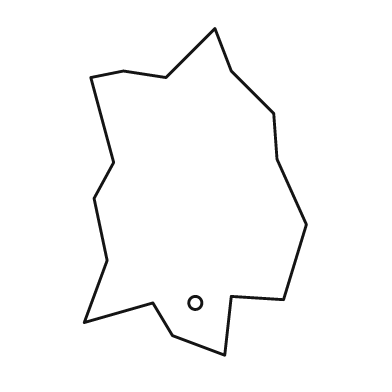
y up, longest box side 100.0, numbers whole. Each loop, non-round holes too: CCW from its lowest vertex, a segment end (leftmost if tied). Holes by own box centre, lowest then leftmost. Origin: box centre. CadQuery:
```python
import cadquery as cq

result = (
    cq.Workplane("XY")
    .moveTo(9.0, -50.0)
    .lineTo(11.0, -32.0)
    .lineTo(27.0, -33.0)
    .lineTo(34.0, -10.0)
    .lineTo(25.0, 10.0)
    .lineTo(24.0, 24.0)
    .lineTo(11.0, 37.0)
    .lineTo(6.0, 50.0)
    .lineTo(-9.0, 35.0)
    .lineTo(-22.0, 37.0)
    .lineTo(-32.0, 35.0)
    .lineTo(-25.0, 9.0)
    .lineTo(-31.0, -2.0)
    .lineTo(-27.0, -21.0)
    .lineTo(-34.0, -40.0)
    .lineTo(-13.0, -34.0)
    .lineTo(-7.0, -44.0)
    .close()
    .moveTo(0.0, -34.0)
    .circle(2.0)
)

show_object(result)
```